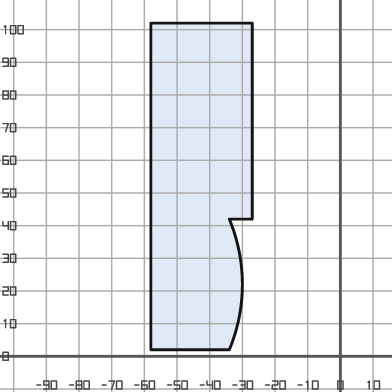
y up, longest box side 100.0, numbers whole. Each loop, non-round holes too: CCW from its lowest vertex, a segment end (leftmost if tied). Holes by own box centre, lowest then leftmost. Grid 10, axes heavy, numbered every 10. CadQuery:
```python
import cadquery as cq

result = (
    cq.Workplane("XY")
    .moveTo(-58.0, 2.0)
    .lineTo(-34.0, 2.0)
    .threePointArc((-30.0, 22.0), (-34.0, 42.0))
    .lineTo(-27.0, 42.0)
    .lineTo(-27.0, 102.0)
    .lineTo(-58.0, 102.0)
    .close()
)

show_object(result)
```